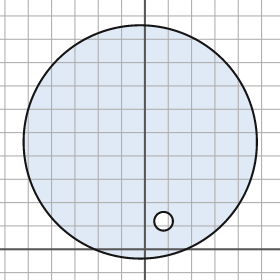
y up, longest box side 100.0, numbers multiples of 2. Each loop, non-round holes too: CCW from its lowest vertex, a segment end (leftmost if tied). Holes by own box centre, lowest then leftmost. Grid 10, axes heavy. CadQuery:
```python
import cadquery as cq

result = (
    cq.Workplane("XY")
    .moveTo(-2.0, 46.0)
    .circle(50.0)
    .moveTo(8.0, 12.0)
    .circle(4.0)
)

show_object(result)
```